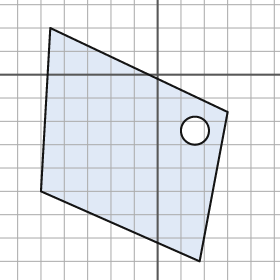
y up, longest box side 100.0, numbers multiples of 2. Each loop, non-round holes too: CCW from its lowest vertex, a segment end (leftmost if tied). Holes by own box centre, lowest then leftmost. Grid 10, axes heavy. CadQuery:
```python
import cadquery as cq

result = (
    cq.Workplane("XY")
    .moveTo(18.0, -80.0)
    .lineTo(30.0, -16.0)
    .lineTo(-46.0, 20.0)
    .lineTo(-50.0, -50.0)
    .close()
    .moveTo(16.0, -24.0)
    .circle(6.0)
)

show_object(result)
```